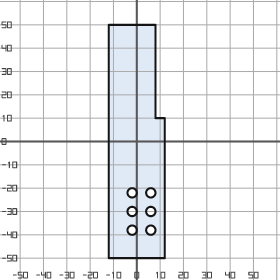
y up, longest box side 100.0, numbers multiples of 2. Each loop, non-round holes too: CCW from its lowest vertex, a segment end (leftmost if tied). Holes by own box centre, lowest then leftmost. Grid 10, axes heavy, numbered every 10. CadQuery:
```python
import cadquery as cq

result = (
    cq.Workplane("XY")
    .moveTo(-12.0, -50.0)
    .lineTo(12.0, -50.0)
    .lineTo(12.0, 10.0)
    .lineTo(8.0, 10.0)
    .lineTo(8.0, 50.0)
    .lineTo(-12.0, 50.0)
    .close()
    .moveTo(-2.0, -38.0)
    .circle(2.0)
    .moveTo(6.0, -38.0)
    .circle(2.0)
    .moveTo(-2.0, -30.0)
    .circle(2.0)
    .moveTo(6.0, -30.0)
    .circle(2.0)
    .moveTo(-2.0, -22.0)
    .circle(2.0)
    .moveTo(6.0, -22.0)
    .circle(2.0)
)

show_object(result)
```